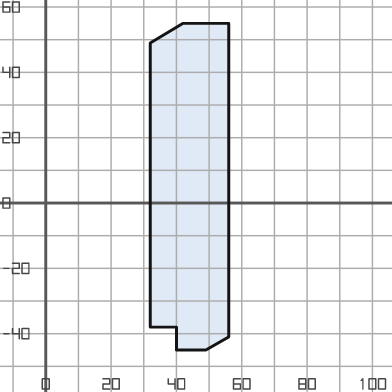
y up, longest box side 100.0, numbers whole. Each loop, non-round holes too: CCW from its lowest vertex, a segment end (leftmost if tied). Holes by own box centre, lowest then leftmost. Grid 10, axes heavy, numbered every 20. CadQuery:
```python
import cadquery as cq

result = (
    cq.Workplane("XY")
    .moveTo(40.0, -45.0)
    .lineTo(49.0, -45.0)
    .lineTo(56.0, -41.0)
    .lineTo(56.0, 55.0)
    .lineTo(42.0, 55.0)
    .lineTo(32.0, 49.0)
    .lineTo(32.0, -38.0)
    .lineTo(40.0, -38.0)
    .close()
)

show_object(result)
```